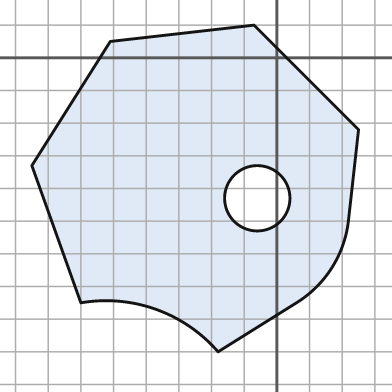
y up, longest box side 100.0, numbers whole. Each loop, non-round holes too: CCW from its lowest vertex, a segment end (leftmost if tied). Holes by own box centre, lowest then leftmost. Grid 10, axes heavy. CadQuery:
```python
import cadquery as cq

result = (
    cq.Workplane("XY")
    .moveTo(-18.0, -90.0)
    .lineTo(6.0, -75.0)
    .threePointArc((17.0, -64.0), (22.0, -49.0))
    .lineTo(25.0, -22.0)
    .lineTo(-7.0, 10.0)
    .lineTo(-51.0, 5.0)
    .lineTo(-75.0, -33.0)
    .lineTo(-60.0, -75.0)
    .threePointArc((-37.0, -77.0), (-18.0, -90.0))
    .close()
    .moveTo(-6.0, -43.0)
    .circle(10.0)
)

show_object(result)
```